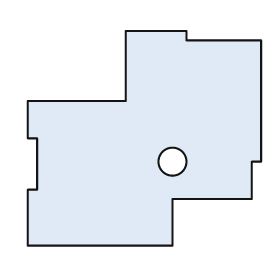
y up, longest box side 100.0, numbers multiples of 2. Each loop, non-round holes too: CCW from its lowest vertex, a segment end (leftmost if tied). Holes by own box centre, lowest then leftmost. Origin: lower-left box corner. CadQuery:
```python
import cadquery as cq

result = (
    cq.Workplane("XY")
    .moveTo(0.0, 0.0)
    .lineTo(62.0, 0.0)
    .lineTo(62.0, 20.0)
    .lineTo(96.0, 20.0)
    .lineTo(96.0, 36.0)
    .lineTo(100.0, 36.0)
    .lineTo(100.0, 88.0)
    .lineTo(68.0, 88.0)
    .lineTo(68.0, 92.0)
    .lineTo(42.0, 92.0)
    .lineTo(42.0, 62.0)
    .lineTo(0.0, 62.0)
    .lineTo(0.0, 46.0)
    .lineTo(4.0, 46.0)
    .lineTo(4.0, 24.0)
    .lineTo(0.0, 24.0)
    .close()
    .moveTo(62.0, 36.0)
    .circle(6.0)
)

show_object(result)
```